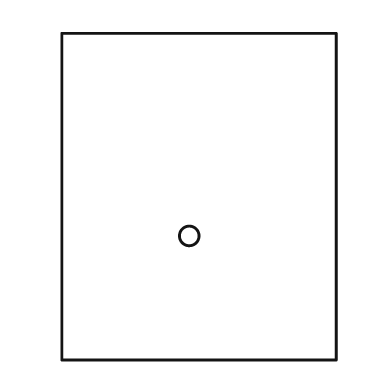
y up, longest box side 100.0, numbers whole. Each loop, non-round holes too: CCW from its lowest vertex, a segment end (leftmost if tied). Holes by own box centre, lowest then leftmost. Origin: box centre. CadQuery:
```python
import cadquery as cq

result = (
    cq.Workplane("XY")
    .moveTo(-42.0, -50.0)
    .lineTo(42.0, -50.0)
    .lineTo(42.0, 50.0)
    .lineTo(-42.0, 50.0)
    .close()
    .moveTo(-3.0, -12.0)
    .circle(3.0)
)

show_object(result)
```